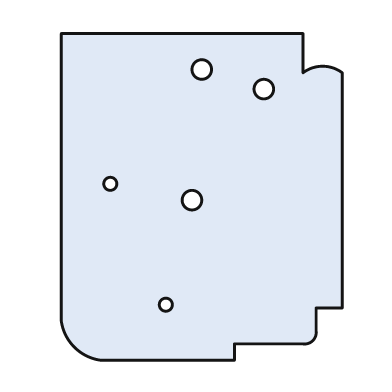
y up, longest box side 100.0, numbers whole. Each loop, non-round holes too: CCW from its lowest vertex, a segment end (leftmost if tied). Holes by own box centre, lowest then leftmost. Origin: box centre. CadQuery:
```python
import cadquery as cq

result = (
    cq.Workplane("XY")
    .moveTo(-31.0, -50.0)
    .lineTo(10.0, -50.0)
    .lineTo(10.0, -45.0)
    .lineTo(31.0, -45.0)
    .threePointArc((34.0, -44.0), (35.0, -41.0))
    .lineTo(35.0, -34.0)
    .lineTo(43.0, -34.0)
    .lineTo(43.0, 38.0)
    .threePointArc((37.0, 40.0), (31.0, 38.0))
    .lineTo(31.0, 50.0)
    .lineTo(-43.0, 50.0)
    .lineTo(-43.0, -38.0)
    .threePointArc((-39.0, -46.0), (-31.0, -50.0))
    .close()
    .moveTo(-11.0, -33.0)
    .circle(2.0)
    .moveTo(-3.0, -1.0)
    .circle(3.0)
    .moveTo(-28.0, 4.0)
    .circle(2.0)
    .moveTo(19.0, 33.0)
    .circle(3.0)
    .moveTo(0.0, 39.0)
    .circle(3.0)
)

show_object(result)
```